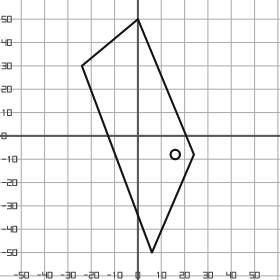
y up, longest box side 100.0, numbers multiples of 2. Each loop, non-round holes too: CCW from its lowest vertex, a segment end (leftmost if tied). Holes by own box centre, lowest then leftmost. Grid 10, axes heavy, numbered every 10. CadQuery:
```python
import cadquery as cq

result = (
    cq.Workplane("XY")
    .moveTo(6.0, -50.0)
    .lineTo(24.0, -8.0)
    .lineTo(0.0, 50.0)
    .lineTo(-24.0, 30.0)
    .close()
    .moveTo(16.0, -8.0)
    .circle(2.0)
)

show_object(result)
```